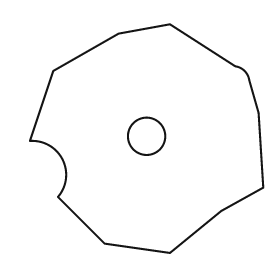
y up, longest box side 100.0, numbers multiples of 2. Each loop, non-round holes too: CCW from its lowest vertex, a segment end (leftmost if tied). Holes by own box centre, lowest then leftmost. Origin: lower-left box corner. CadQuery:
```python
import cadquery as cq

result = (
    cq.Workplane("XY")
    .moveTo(60.0, 0.0)
    .lineTo(82.0, 18.0)
    .lineTo(100.0, 28.0)
    .lineTo(98.0, 60.0)
    .lineTo(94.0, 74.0)
    .threePointArc((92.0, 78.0), (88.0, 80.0))
    .lineTo(60.0, 98.0)
    .lineTo(38.0, 94.0)
    .lineTo(10.0, 78.0)
    .lineTo(0.0, 48.0)
    .threePointArc((14.0, 40.0), (12.0, 24.0))
    .lineTo(32.0, 4.0)
    .close()
    .moveTo(50.0, 50.0)
    .circle(8.0)
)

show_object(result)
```